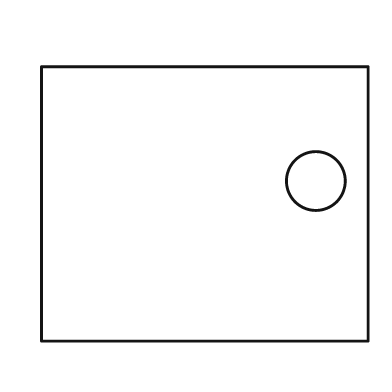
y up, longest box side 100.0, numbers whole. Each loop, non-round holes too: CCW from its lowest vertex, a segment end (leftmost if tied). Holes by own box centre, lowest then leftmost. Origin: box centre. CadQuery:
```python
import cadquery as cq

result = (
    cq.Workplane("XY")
    .moveTo(-50.0, -42.0)
    .lineTo(50.0, -42.0)
    .lineTo(50.0, 42.0)
    .lineTo(-50.0, 42.0)
    .close()
    .moveTo(34.0, 7.0)
    .circle(9.0)
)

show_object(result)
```